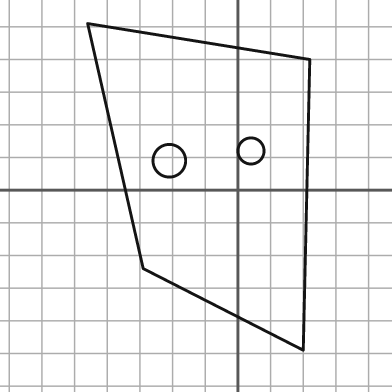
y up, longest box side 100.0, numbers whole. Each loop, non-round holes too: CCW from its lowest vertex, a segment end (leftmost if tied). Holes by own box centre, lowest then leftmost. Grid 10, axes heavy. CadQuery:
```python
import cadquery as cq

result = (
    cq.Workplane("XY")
    .moveTo(20.0, -49.0)
    .lineTo(22.0, 40.0)
    .lineTo(-46.0, 51.0)
    .lineTo(-29.0, -24.0)
    .close()
    .moveTo(-21.0, 9.0)
    .circle(5.0)
    .moveTo(4.0, 12.0)
    .circle(4.0)
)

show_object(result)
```